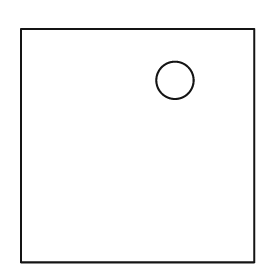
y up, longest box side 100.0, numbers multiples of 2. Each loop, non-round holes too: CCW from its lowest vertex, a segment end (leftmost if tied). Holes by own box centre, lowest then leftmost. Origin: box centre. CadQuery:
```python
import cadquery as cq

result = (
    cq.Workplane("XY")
    .moveTo(-50.0, -50.0)
    .lineTo(50.0, -50.0)
    .lineTo(50.0, 50.0)
    .lineTo(-50.0, 50.0)
    .close()
    .moveTo(16.0, 28.0)
    .circle(8.0)
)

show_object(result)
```